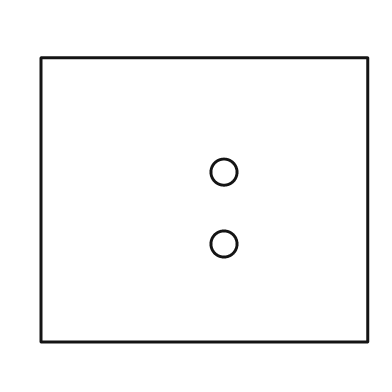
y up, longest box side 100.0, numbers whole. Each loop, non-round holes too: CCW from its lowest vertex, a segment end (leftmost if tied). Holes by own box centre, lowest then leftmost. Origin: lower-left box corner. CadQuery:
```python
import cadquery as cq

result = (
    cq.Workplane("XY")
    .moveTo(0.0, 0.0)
    .lineTo(100.0, 0.0)
    .lineTo(100.0, 87.0)
    .lineTo(0.0, 87.0)
    .close()
    .moveTo(56.0, 30.0)
    .circle(4.0)
    .moveTo(56.0, 52.0)
    .circle(4.0)
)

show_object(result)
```